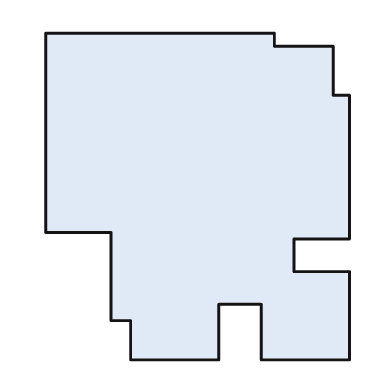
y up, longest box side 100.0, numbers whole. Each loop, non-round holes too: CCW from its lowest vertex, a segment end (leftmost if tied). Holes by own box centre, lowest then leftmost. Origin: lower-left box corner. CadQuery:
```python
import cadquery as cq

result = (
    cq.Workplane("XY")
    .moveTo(26.0, 0.0)
    .lineTo(53.0, 0.0)
    .lineTo(53.0, 17.0)
    .lineTo(66.0, 17.0)
    .lineTo(66.0, 0.0)
    .lineTo(93.0, 0.0)
    .lineTo(93.0, 27.0)
    .lineTo(76.0, 27.0)
    .lineTo(76.0, 37.0)
    .lineTo(93.0, 37.0)
    .lineTo(93.0, 81.0)
    .lineTo(88.0, 81.0)
    .lineTo(88.0, 96.0)
    .lineTo(70.0, 96.0)
    .lineTo(70.0, 100.0)
    .lineTo(0.0, 100.0)
    .lineTo(0.0, 39.0)
    .lineTo(20.0, 39.0)
    .lineTo(20.0, 12.0)
    .lineTo(26.0, 12.0)
    .close()
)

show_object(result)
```